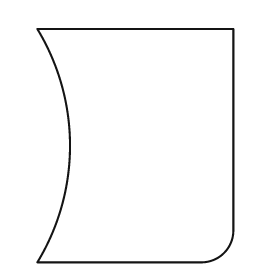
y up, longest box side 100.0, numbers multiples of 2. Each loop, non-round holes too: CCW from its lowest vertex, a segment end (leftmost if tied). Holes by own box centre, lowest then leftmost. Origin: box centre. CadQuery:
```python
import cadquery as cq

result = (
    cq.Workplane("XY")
    .moveTo(-42.0, -50.0)
    .lineTo(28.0, -50.0)
    .threePointArc((38.0, -46.0), (42.0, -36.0))
    .lineTo(42.0, 50.0)
    .lineTo(-42.0, 50.0)
    .threePointArc((-28.0, 0.0), (-42.0, -50.0))
    .close()
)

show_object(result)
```